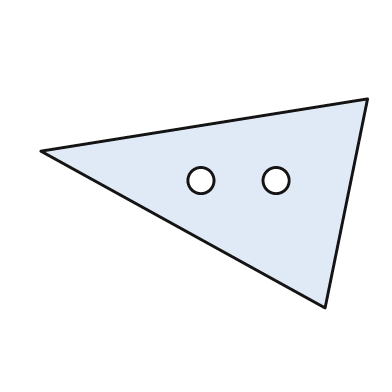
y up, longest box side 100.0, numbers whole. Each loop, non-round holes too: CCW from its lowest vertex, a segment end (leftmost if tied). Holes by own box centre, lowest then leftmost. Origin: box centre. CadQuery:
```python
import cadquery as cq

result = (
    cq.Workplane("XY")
    .moveTo(37.0, -32.0)
    .lineTo(50.0, 32.0)
    .lineTo(-50.0, 16.0)
    .close()
    .moveTo(-1.0, 7.0)
    .circle(4.0)
    .moveTo(22.0, 7.0)
    .circle(4.0)
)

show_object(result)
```